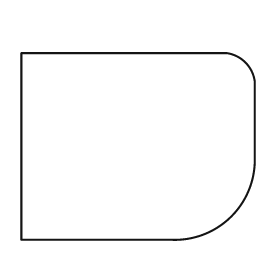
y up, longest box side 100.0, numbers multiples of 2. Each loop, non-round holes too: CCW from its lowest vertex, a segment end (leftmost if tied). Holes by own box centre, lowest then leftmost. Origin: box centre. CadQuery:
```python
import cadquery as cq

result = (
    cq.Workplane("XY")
    .moveTo(-50.0, -40.0)
    .lineTo(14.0, -40.0)
    .threePointArc((40.0, -30.0), (50.0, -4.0))
    .lineTo(50.0, 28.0)
    .threePointArc((46.0, 36.0), (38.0, 40.0))
    .lineTo(-50.0, 40.0)
    .close()
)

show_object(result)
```